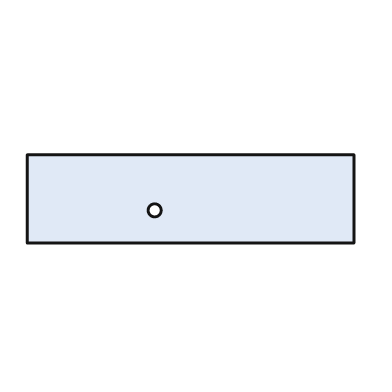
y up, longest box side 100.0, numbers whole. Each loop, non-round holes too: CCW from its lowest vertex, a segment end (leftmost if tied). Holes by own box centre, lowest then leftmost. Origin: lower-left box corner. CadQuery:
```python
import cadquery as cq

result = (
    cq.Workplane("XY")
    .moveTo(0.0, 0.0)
    .lineTo(100.0, 0.0)
    .lineTo(100.0, 27.0)
    .lineTo(0.0, 27.0)
    .close()
    .moveTo(39.0, 10.0)
    .circle(2.0)
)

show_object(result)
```